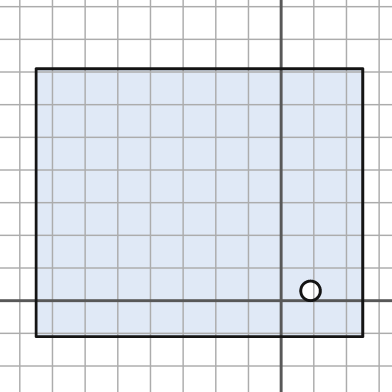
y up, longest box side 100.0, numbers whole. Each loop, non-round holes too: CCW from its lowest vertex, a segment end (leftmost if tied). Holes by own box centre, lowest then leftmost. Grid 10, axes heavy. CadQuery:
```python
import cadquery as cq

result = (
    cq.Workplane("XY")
    .moveTo(-75.0, -11.0)
    .lineTo(25.0, -11.0)
    .lineTo(25.0, 71.0)
    .lineTo(-75.0, 71.0)
    .close()
    .moveTo(9.0, 3.0)
    .circle(3.0)
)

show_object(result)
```